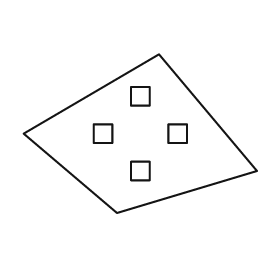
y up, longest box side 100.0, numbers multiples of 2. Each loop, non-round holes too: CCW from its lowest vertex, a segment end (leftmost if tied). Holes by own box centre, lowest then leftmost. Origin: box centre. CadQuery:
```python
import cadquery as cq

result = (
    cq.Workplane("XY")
    .moveTo(-10.0, -34.0)
    .lineTo(50.0, -16.0)
    .lineTo(8.0, 34.0)
    .lineTo(-50.0, 0.0)
    .close()
    .moveTo(-4.0, -20.0)
    .lineTo(4.0, -20.0)
    .lineTo(4.0, -12.0)
    .lineTo(-4.0, -12.0)
    .close()
    .moveTo(-20.0, -4.0)
    .lineTo(-12.0, -4.0)
    .lineTo(-12.0, 4.0)
    .lineTo(-20.0, 4.0)
    .close()
    .moveTo(12.0, -4.0)
    .lineTo(20.0, -4.0)
    .lineTo(20.0, 4.0)
    .lineTo(12.0, 4.0)
    .close()
    .moveTo(-4.0, 12.0)
    .lineTo(4.0, 12.0)
    .lineTo(4.0, 20.0)
    .lineTo(-4.0, 20.0)
    .close()
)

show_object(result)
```